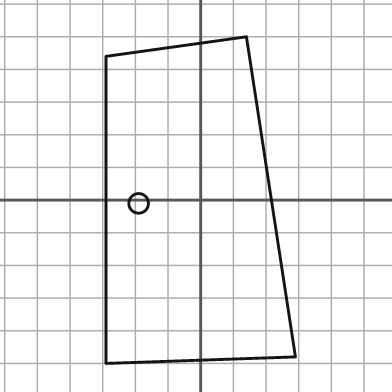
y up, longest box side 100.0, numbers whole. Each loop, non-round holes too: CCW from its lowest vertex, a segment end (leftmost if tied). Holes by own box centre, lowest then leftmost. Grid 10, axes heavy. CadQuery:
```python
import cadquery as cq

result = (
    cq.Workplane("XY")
    .moveTo(-29.0, -50.0)
    .lineTo(29.0, -48.0)
    .lineTo(14.0, 50.0)
    .lineTo(-29.0, 44.0)
    .close()
    .moveTo(-19.0, -1.0)
    .circle(3.0)
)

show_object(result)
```